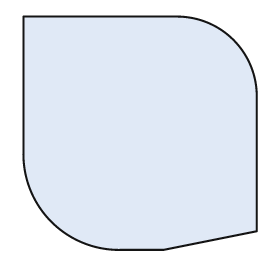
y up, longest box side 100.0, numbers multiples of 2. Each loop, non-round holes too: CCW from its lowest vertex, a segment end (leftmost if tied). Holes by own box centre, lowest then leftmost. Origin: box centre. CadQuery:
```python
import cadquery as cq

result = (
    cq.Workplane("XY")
    .moveTo(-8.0, -50.0)
    .lineTo(10.0, -50.0)
    .lineTo(50.0, -42.0)
    .lineTo(50.0, 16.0)
    .threePointArc((40.0, 40.0), (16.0, 50.0))
    .lineTo(-50.0, 50.0)
    .lineTo(-50.0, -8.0)
    .threePointArc((-38.0, -38.0), (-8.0, -50.0))
    .close()
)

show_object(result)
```